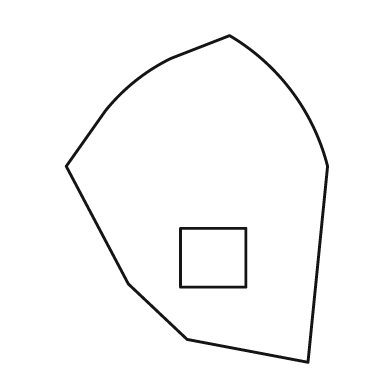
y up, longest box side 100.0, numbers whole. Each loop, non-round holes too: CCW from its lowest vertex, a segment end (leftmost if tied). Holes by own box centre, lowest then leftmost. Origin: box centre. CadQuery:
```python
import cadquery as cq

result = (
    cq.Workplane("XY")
    .moveTo(34.0, -50.0)
    .lineTo(40.0, 10.0)
    .threePointArc((29.0, 33.0), (10.0, 50.0))
    .lineTo(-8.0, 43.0)
    .threePointArc((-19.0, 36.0), (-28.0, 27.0))
    .lineTo(-40.0, 10.0)
    .lineTo(-21.0, -26.0)
    .lineTo(-3.0, -43.0)
    .close()
    .moveTo(-5.0, -27.0)
    .lineTo(15.0, -27.0)
    .lineTo(15.0, -9.0)
    .lineTo(-5.0, -9.0)
    .close()
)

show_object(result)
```